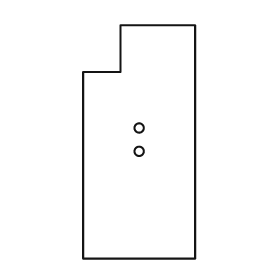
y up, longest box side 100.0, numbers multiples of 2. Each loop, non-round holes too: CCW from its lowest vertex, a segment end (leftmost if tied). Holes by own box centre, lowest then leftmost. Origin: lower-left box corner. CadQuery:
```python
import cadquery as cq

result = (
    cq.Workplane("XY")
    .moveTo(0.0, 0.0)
    .lineTo(48.0, 0.0)
    .lineTo(48.0, 100.0)
    .lineTo(16.0, 100.0)
    .lineTo(16.0, 80.0)
    .lineTo(0.0, 80.0)
    .close()
    .moveTo(24.0, 46.0)
    .circle(2.0)
    .moveTo(24.0, 56.0)
    .circle(2.0)
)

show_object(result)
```